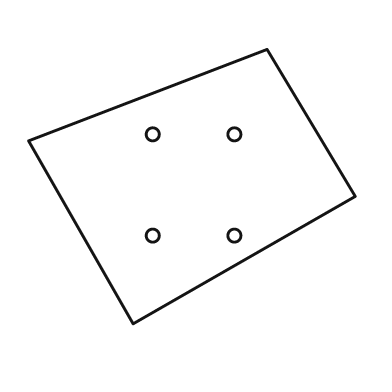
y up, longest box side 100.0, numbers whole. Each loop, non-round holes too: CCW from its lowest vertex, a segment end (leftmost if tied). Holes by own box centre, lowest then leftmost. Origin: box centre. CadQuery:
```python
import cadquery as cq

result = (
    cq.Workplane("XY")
    .moveTo(-18.0, -42.0)
    .lineTo(50.0, -3.0)
    .lineTo(23.0, 42.0)
    .lineTo(-50.0, 14.0)
    .close()
    .moveTo(-12.0, -15.0)
    .circle(2.0)
    .moveTo(13.0, -15.0)
    .circle(2.0)
    .moveTo(-12.0, 16.0)
    .circle(2.0)
    .moveTo(13.0, 16.0)
    .circle(2.0)
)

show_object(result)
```